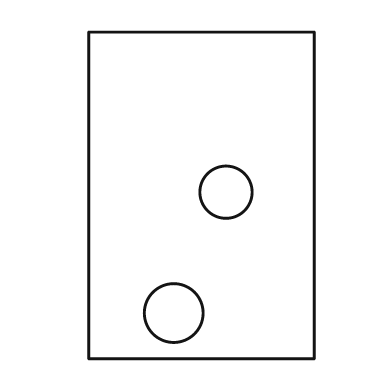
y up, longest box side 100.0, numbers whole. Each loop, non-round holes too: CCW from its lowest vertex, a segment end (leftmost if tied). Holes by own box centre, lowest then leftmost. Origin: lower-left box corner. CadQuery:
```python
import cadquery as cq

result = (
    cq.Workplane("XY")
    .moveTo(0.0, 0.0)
    .lineTo(69.0, 0.0)
    .lineTo(69.0, 100.0)
    .lineTo(0.0, 100.0)
    .close()
    .moveTo(26.0, 14.0)
    .circle(9.0)
    .moveTo(42.0, 51.0)
    .circle(8.0)
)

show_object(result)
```